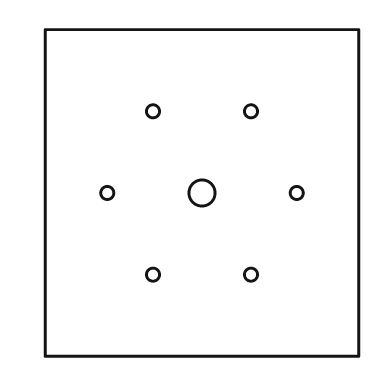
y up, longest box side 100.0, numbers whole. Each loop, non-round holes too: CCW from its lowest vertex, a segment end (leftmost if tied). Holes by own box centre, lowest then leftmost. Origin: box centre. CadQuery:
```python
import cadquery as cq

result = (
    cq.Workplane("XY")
    .moveTo(-48.0, -50.0)
    .lineTo(48.0, -50.0)
    .lineTo(48.0, 50.0)
    .lineTo(-48.0, 50.0)
    .close()
    .moveTo(-15.0, -25.0)
    .circle(2.0)
    .moveTo(15.0, -25.0)
    .circle(2.0)
    .moveTo(-29.0, 0.0)
    .circle(2.0)
    .moveTo(0.0, 0.0)
    .circle(4.0)
    .moveTo(29.0, 0.0)
    .circle(2.0)
    .moveTo(-15.0, 25.0)
    .circle(2.0)
    .moveTo(15.0, 25.0)
    .circle(2.0)
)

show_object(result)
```